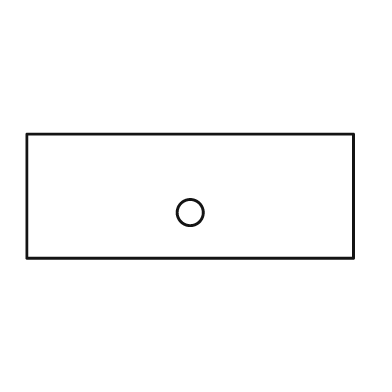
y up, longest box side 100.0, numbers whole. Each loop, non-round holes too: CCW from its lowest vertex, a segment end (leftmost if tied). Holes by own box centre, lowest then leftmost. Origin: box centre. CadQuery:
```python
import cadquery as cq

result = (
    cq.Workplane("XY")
    .moveTo(-50.0, -19.0)
    .lineTo(50.0, -19.0)
    .lineTo(50.0, 19.0)
    .lineTo(-50.0, 19.0)
    .close()
    .moveTo(0.0, -5.0)
    .circle(4.0)
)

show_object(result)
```